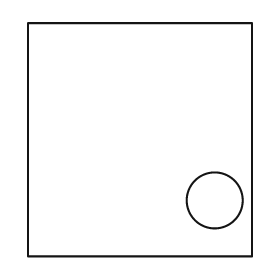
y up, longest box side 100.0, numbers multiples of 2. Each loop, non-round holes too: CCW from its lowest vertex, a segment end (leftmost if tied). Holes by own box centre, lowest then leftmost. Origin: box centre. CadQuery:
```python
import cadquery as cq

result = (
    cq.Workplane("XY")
    .moveTo(-48.0, -50.0)
    .lineTo(48.0, -50.0)
    .lineTo(48.0, 50.0)
    .lineTo(-48.0, 50.0)
    .close()
    .moveTo(32.0, -26.0)
    .circle(12.0)
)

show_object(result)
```